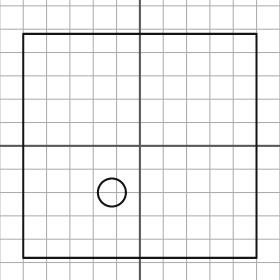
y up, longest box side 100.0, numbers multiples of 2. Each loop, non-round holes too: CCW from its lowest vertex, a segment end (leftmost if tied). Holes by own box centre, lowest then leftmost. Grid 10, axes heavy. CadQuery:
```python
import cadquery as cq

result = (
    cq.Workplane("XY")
    .moveTo(-50.0, -48.0)
    .lineTo(50.0, -48.0)
    .lineTo(50.0, 48.0)
    .lineTo(-50.0, 48.0)
    .close()
    .moveTo(-12.0, -20.0)
    .circle(6.0)
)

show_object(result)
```